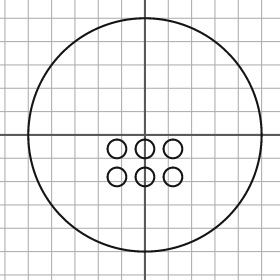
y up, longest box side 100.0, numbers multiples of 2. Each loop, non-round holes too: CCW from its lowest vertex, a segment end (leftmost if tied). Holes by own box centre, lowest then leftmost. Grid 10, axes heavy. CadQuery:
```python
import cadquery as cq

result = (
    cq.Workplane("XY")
    .moveTo(0.0, 0.0)
    .circle(50.0)
    .moveTo(-12.0, -18.0)
    .circle(4.0)
    .moveTo(0.0, -18.0)
    .circle(4.0)
    .moveTo(12.0, -18.0)
    .circle(4.0)
    .moveTo(-12.0, -6.0)
    .circle(4.0)
    .moveTo(0.0, -6.0)
    .circle(4.0)
    .moveTo(12.0, -6.0)
    .circle(4.0)
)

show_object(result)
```